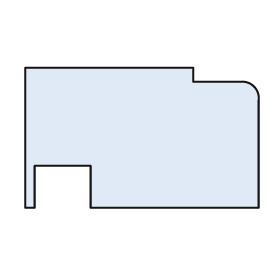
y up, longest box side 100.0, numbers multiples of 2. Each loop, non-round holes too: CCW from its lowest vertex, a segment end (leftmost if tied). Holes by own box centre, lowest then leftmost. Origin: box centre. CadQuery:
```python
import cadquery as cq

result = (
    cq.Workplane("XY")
    .moveTo(-50.0, -30.0)
    .lineTo(-46.0, -30.0)
    .lineTo(-46.0, -12.0)
    .lineTo(-22.0, -12.0)
    .lineTo(-22.0, -30.0)
    .lineTo(50.0, -30.0)
    .lineTo(50.0, 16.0)
    .threePointArc((48.0, 22.0), (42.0, 24.0))
    .lineTo(22.0, 24.0)
    .lineTo(22.0, 30.0)
    .lineTo(-50.0, 30.0)
    .close()
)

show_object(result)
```